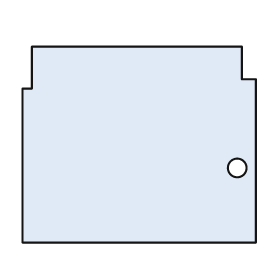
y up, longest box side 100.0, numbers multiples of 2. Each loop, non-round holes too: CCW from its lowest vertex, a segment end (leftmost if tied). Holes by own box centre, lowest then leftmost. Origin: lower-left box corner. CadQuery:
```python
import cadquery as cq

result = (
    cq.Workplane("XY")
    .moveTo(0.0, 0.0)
    .lineTo(100.0, 0.0)
    .lineTo(100.0, 70.0)
    .lineTo(94.0, 70.0)
    .lineTo(94.0, 84.0)
    .lineTo(4.0, 84.0)
    .lineTo(4.0, 66.0)
    .lineTo(0.0, 66.0)
    .close()
    .moveTo(92.0, 32.0)
    .circle(4.0)
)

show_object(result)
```